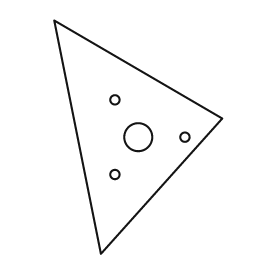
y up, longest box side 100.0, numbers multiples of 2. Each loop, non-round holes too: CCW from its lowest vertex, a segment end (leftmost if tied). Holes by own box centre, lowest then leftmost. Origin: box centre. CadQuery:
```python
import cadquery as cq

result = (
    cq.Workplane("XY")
    .moveTo(-16.0, -50.0)
    .lineTo(36.0, 8.0)
    .lineTo(-36.0, 50.0)
    .close()
    .moveTo(-10.0, -16.0)
    .circle(2.0)
    .moveTo(0.0, 0.0)
    .circle(6.0)
    .moveTo(20.0, 0.0)
    .circle(2.0)
    .moveTo(-10.0, 16.0)
    .circle(2.0)
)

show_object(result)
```